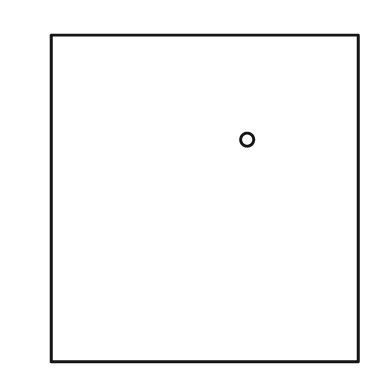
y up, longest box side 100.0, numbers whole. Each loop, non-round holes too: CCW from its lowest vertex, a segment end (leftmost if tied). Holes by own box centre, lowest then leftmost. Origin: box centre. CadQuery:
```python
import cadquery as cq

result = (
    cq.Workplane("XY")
    .moveTo(-47.0, -50.0)
    .lineTo(47.0, -50.0)
    .lineTo(47.0, 50.0)
    .lineTo(-47.0, 50.0)
    .close()
    .moveTo(13.0, 18.0)
    .circle(2.0)
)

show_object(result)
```